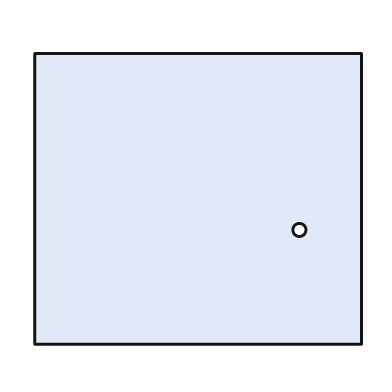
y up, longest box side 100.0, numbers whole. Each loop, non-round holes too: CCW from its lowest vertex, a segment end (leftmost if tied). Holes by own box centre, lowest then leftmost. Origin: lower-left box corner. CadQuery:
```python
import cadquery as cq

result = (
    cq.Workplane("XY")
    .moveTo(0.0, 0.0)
    .lineTo(100.0, 0.0)
    .lineTo(100.0, 89.0)
    .lineTo(0.0, 89.0)
    .close()
    .moveTo(81.0, 35.0)
    .circle(2.0)
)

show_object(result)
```